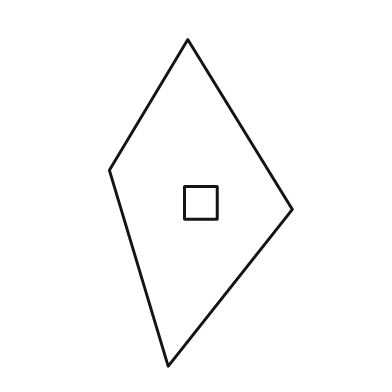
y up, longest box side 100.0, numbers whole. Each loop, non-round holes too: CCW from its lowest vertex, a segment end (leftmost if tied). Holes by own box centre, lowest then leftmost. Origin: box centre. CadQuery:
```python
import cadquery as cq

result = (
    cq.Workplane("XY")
    .moveTo(-10.0, -50.0)
    .lineTo(28.0, -2.0)
    .lineTo(-4.0, 50.0)
    .lineTo(-28.0, 10.0)
    .close()
    .moveTo(-5.0, -5.0)
    .lineTo(5.0, -5.0)
    .lineTo(5.0, 5.0)
    .lineTo(-5.0, 5.0)
    .close()
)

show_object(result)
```